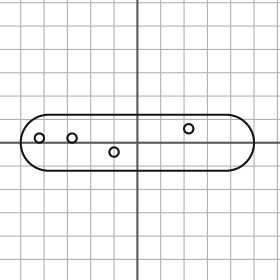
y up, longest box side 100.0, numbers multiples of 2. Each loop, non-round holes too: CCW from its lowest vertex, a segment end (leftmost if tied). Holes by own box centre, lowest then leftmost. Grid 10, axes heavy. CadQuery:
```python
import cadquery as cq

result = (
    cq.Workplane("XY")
    .moveTo(-38.0, -12.0)
    .lineTo(38.0, -12.0)
    .threePointArc((50.0, 0.0), (38.0, 12.0))
    .lineTo(-38.0, 12.0)
    .threePointArc((-50.0, 0.0), (-38.0, -12.0))
    .close()
    .moveTo(-10.0, -4.0)
    .circle(2.0)
    .moveTo(-42.0, 2.0)
    .circle(2.0)
    .moveTo(-28.0, 2.0)
    .circle(2.0)
    .moveTo(22.0, 6.0)
    .circle(2.0)
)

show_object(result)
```